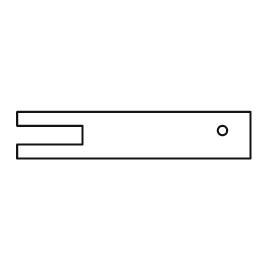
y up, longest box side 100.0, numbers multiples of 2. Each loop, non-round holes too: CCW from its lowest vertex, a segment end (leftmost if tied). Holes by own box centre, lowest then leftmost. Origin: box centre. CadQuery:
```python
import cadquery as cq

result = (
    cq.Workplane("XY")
    .moveTo(-50.0, -10.0)
    .lineTo(50.0, -10.0)
    .lineTo(50.0, 10.0)
    .lineTo(-50.0, 10.0)
    .lineTo(-50.0, 4.0)
    .lineTo(-22.0, 4.0)
    .lineTo(-22.0, -4.0)
    .lineTo(-50.0, -4.0)
    .close()
    .moveTo(38.0, 2.0)
    .circle(2.0)
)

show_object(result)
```